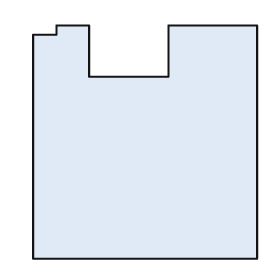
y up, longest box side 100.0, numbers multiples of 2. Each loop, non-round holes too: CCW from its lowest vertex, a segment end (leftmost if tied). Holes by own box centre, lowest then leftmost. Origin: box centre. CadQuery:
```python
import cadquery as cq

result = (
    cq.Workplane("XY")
    .moveTo(-48.0, -50.0)
    .lineTo(48.0, -50.0)
    .lineTo(48.0, 50.0)
    .lineTo(10.0, 50.0)
    .lineTo(10.0, 28.0)
    .lineTo(-24.0, 28.0)
    .lineTo(-24.0, 50.0)
    .lineTo(-38.0, 50.0)
    .lineTo(-38.0, 46.0)
    .lineTo(-48.0, 46.0)
    .close()
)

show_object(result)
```